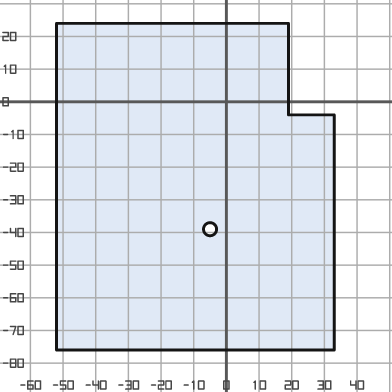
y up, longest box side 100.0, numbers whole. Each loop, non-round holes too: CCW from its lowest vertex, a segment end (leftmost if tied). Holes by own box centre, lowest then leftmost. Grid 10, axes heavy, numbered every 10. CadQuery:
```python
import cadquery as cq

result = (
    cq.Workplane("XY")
    .moveTo(-52.0, -76.0)
    .lineTo(33.0, -76.0)
    .lineTo(33.0, -4.0)
    .lineTo(19.0, -4.0)
    .lineTo(19.0, 24.0)
    .lineTo(-52.0, 24.0)
    .close()
    .moveTo(-5.0, -39.0)
    .circle(2.0)
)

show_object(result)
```